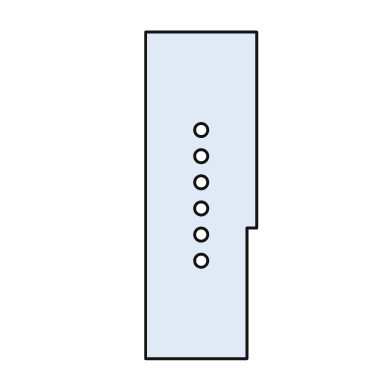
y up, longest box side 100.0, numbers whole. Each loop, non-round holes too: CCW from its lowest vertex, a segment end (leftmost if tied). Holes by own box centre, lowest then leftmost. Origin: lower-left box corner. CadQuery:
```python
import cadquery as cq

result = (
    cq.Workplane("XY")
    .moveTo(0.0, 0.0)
    .lineTo(31.0, 0.0)
    .lineTo(31.0, 40.0)
    .lineTo(34.0, 40.0)
    .lineTo(34.0, 100.0)
    .lineTo(0.0, 100.0)
    .close()
    .moveTo(17.0, 30.0)
    .circle(2.0)
    .moveTo(17.0, 38.0)
    .circle(2.0)
    .moveTo(17.0, 46.0)
    .circle(2.0)
    .moveTo(17.0, 54.0)
    .circle(2.0)
    .moveTo(17.0, 62.0)
    .circle(2.0)
    .moveTo(17.0, 70.0)
    .circle(2.0)
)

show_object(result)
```